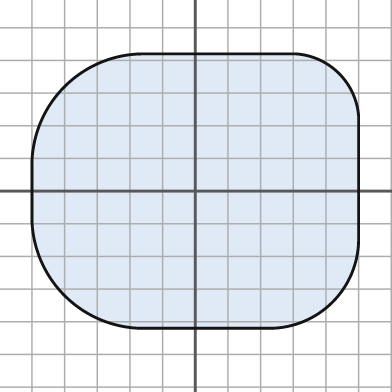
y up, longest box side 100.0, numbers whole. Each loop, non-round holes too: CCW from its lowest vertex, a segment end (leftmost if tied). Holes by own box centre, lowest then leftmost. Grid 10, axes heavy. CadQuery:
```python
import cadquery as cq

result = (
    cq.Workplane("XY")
    .moveTo(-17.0, -42.0)
    .lineTo(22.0, -42.0)
    .threePointArc((42.0, -34.0), (50.0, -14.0))
    .lineTo(50.0, 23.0)
    .threePointArc((44.0, 36.0), (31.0, 42.0))
    .lineTo(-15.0, 42.0)
    .threePointArc((-40.0, 32.0), (-50.0, 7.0))
    .lineTo(-50.0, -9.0)
    .threePointArc((-40.0, -32.0), (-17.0, -42.0))
    .close()
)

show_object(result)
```